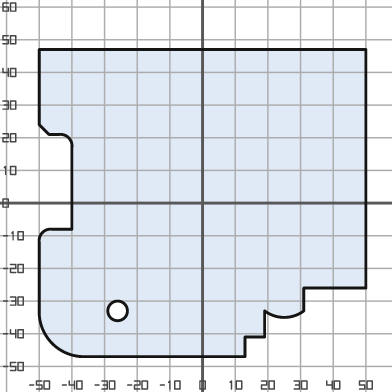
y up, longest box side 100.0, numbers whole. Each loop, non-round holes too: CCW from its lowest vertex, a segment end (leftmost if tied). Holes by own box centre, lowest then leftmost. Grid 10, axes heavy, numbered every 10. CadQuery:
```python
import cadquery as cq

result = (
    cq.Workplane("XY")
    .moveTo(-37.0, -47.0)
    .lineTo(13.0, -47.0)
    .lineTo(13.0, -41.0)
    .lineTo(19.0, -41.0)
    .lineTo(19.0, -33.0)
    .threePointArc((25.0, -35.0), (31.0, -33.0))
    .lineTo(31.0, -26.0)
    .lineTo(50.0, -26.0)
    .lineTo(50.0, 47.0)
    .lineTo(-50.0, 47.0)
    .lineTo(-50.0, 24.0)
    .lineTo(-47.0, 21.0)
    .lineTo(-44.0, 21.0)
    .threePointArc((-41.0, 20.0), (-40.0, 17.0))
    .lineTo(-40.0, -8.0)
    .lineTo(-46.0, -8.0)
    .threePointArc((-49.0, -9.0), (-50.0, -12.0))
    .lineTo(-50.0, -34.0)
    .threePointArc((-46.0, -43.0), (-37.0, -47.0))
    .close()
    .moveTo(-26.0, -33.0)
    .circle(3.0)
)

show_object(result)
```